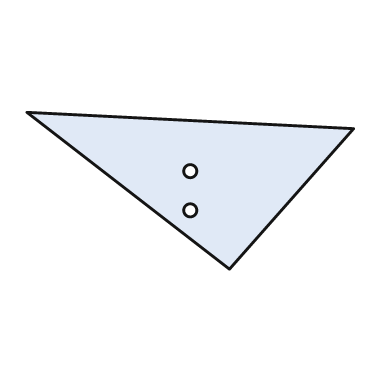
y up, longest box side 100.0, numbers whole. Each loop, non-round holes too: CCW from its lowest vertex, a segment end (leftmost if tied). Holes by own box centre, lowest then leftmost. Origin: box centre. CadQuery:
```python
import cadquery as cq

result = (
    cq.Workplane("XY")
    .moveTo(12.0, -24.0)
    .lineTo(50.0, 19.0)
    .lineTo(-50.0, 24.0)
    .close()
    .moveTo(0.0, -6.0)
    .circle(2.0)
    .moveTo(0.0, 6.0)
    .circle(2.0)
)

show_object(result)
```